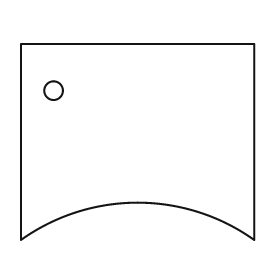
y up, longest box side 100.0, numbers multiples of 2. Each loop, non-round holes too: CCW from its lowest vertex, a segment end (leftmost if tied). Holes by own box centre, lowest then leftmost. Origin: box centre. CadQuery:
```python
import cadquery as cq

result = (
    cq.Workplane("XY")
    .moveTo(-50.0, -42.0)
    .threePointArc((0.0, -26.0), (50.0, -42.0))
    .lineTo(50.0, 42.0)
    .lineTo(-50.0, 42.0)
    .close()
    .moveTo(-36.0, 22.0)
    .circle(4.0)
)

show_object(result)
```